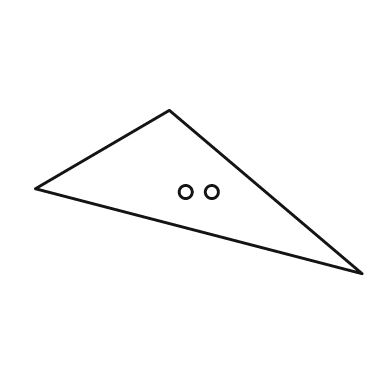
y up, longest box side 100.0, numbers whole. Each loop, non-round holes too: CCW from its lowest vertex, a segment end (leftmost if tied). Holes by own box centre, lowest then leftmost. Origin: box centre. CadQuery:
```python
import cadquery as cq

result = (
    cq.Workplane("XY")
    .moveTo(50.0, -25.0)
    .lineTo(-9.0, 25.0)
    .lineTo(-50.0, 1.0)
    .close()
    .moveTo(-4.0, 0.0)
    .circle(2.0)
    .moveTo(4.0, 0.0)
    .circle(2.0)
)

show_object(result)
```